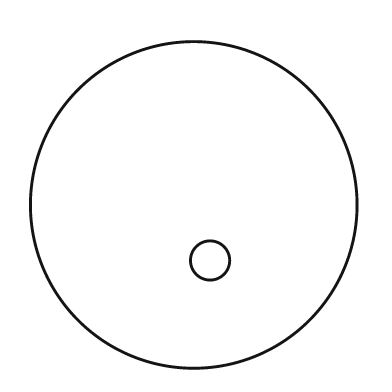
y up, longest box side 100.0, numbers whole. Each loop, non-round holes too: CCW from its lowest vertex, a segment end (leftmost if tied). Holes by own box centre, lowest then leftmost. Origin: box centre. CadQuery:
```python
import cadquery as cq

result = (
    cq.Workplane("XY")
    .moveTo(0.0, 0.0)
    .circle(50.0)
    .moveTo(5.0, -17.0)
    .circle(6.0)
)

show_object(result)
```